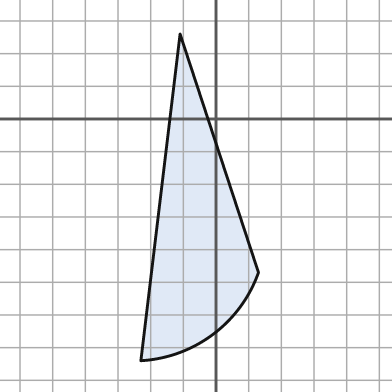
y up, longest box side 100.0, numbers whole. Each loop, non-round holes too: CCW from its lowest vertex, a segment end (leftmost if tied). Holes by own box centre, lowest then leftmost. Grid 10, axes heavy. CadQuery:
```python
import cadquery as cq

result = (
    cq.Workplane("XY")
    .moveTo(-23.0, -74.0)
    .threePointArc((-1.0, -66.0), (13.0, -47.0))
    .lineTo(-11.0, 26.0)
    .close()
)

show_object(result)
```